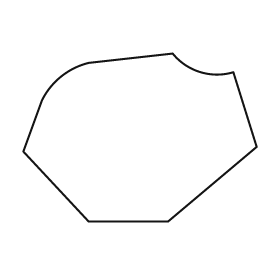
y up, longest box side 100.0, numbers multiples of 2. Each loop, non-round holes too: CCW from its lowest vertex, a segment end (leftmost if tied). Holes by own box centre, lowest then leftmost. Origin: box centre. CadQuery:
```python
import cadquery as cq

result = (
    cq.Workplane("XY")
    .moveTo(-22.0, -36.0)
    .lineTo(12.0, -36.0)
    .lineTo(50.0, -4.0)
    .lineTo(40.0, 28.0)
    .threePointArc((26.0, 28.0), (14.0, 36.0))
    .lineTo(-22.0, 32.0)
    .threePointArc((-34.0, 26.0), (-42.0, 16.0))
    .lineTo(-50.0, -6.0)
    .close()
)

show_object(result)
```